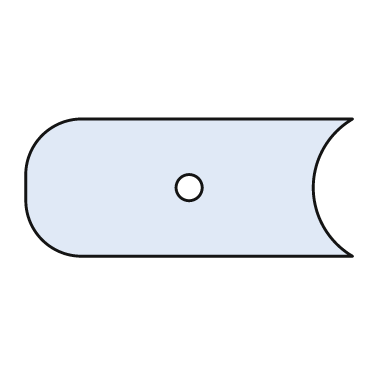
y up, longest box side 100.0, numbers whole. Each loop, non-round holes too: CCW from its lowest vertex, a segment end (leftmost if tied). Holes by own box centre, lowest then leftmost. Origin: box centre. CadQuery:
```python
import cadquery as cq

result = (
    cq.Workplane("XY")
    .moveTo(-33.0, -21.0)
    .lineTo(50.0, -21.0)
    .threePointArc((38.0, 0.0), (50.0, 21.0))
    .lineTo(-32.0, 21.0)
    .threePointArc((-45.0, 16.0), (-50.0, 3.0))
    .lineTo(-50.0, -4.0)
    .threePointArc((-45.0, -16.0), (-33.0, -21.0))
    .close()
    .moveTo(0.0, 0.0)
    .circle(4.0)
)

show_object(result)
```